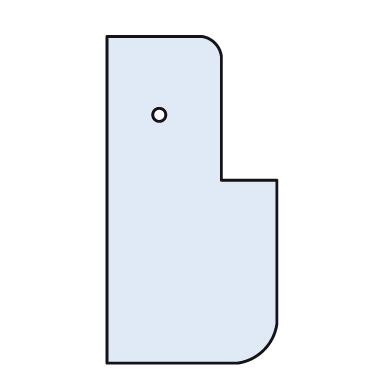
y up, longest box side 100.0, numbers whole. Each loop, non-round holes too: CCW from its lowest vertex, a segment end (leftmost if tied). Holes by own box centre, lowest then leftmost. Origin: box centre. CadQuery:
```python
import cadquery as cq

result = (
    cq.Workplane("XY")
    .moveTo(-26.0, -50.0)
    .lineTo(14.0, -50.0)
    .threePointArc((22.0, -46.0), (26.0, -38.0))
    .lineTo(26.0, 6.0)
    .lineTo(9.0, 6.0)
    .lineTo(9.0, 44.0)
    .threePointArc((7.0, 48.0), (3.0, 50.0))
    .lineTo(-26.0, 50.0)
    .close()
    .moveTo(-10.0, 26.0)
    .circle(2.0)
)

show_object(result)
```